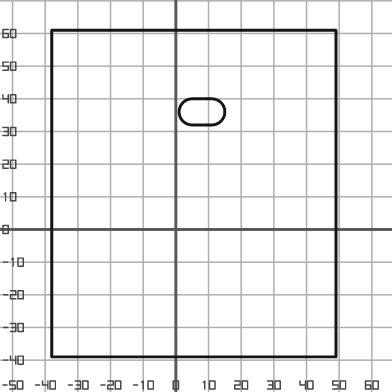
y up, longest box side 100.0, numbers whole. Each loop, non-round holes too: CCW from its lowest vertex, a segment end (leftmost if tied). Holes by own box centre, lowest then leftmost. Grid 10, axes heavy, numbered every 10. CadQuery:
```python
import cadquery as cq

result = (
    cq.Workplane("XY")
    .moveTo(-38.0, -39.0)
    .lineTo(49.0, -39.0)
    .lineTo(49.0, 61.0)
    .lineTo(-38.0, 61.0)
    .close()
    .moveTo(5.0, 32.0)
    .lineTo(11.0, 32.0)
    .threePointArc((15.0, 36.0), (11.0, 40.0))
    .lineTo(5.0, 40.0)
    .threePointArc((1.0, 36.0), (5.0, 32.0))
    .close()
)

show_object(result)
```